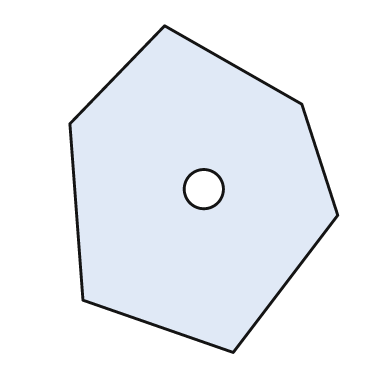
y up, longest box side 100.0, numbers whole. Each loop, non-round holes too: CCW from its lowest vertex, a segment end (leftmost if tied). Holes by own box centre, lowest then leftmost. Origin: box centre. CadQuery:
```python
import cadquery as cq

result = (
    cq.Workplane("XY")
    .moveTo(9.0, -50.0)
    .lineTo(41.0, -8.0)
    .lineTo(30.0, 26.0)
    .lineTo(-12.0, 50.0)
    .lineTo(-41.0, 20.0)
    .lineTo(-37.0, -34.0)
    .close()
    .moveTo(0.0, 0.0)
    .circle(6.0)
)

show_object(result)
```